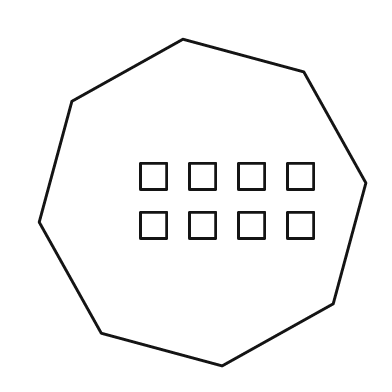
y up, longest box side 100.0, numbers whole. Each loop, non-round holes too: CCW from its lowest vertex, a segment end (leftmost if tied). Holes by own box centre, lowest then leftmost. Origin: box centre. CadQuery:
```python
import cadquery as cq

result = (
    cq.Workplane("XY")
    .moveTo(6.0, -50.0)
    .lineTo(40.0, -31.0)
    .lineTo(50.0, 6.0)
    .lineTo(31.0, 40.0)
    .lineTo(-6.0, 50.0)
    .lineTo(-40.0, 31.0)
    .lineTo(-50.0, -6.0)
    .lineTo(-31.0, -40.0)
    .close()
    .moveTo(-19.0, -11.0)
    .lineTo(-11.0, -11.0)
    .lineTo(-11.0, -3.0)
    .lineTo(-19.0, -3.0)
    .close()
    .moveTo(-4.0, -11.0)
    .lineTo(4.0, -11.0)
    .lineTo(4.0, -3.0)
    .lineTo(-4.0, -3.0)
    .close()
    .moveTo(11.0, -11.0)
    .lineTo(19.0, -11.0)
    .lineTo(19.0, -3.0)
    .lineTo(11.0, -3.0)
    .close()
    .moveTo(26.0, -11.0)
    .lineTo(34.0, -11.0)
    .lineTo(34.0, -3.0)
    .lineTo(26.0, -3.0)
    .close()
    .moveTo(-19.0, 4.0)
    .lineTo(-11.0, 4.0)
    .lineTo(-11.0, 12.0)
    .lineTo(-19.0, 12.0)
    .close()
    .moveTo(-4.0, 4.0)
    .lineTo(4.0, 4.0)
    .lineTo(4.0, 12.0)
    .lineTo(-4.0, 12.0)
    .close()
    .moveTo(11.0, 4.0)
    .lineTo(19.0, 4.0)
    .lineTo(19.0, 12.0)
    .lineTo(11.0, 12.0)
    .close()
    .moveTo(26.0, 4.0)
    .lineTo(34.0, 4.0)
    .lineTo(34.0, 12.0)
    .lineTo(26.0, 12.0)
    .close()
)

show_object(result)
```